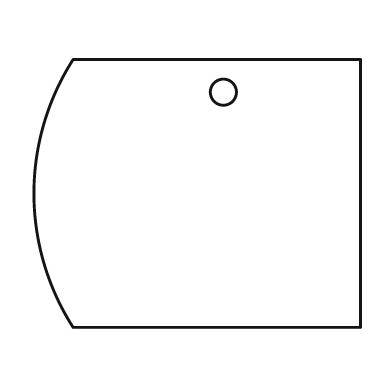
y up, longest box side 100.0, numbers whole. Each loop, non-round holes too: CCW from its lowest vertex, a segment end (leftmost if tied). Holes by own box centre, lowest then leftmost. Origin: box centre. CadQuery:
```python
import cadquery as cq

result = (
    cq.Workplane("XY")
    .moveTo(-38.0, -41.0)
    .lineTo(50.0, -41.0)
    .lineTo(50.0, 41.0)
    .lineTo(-38.0, 41.0)
    .threePointArc((-50.0, 0.0), (-38.0, -41.0))
    .close()
    .moveTo(8.0, 31.0)
    .circle(4.0)
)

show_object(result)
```